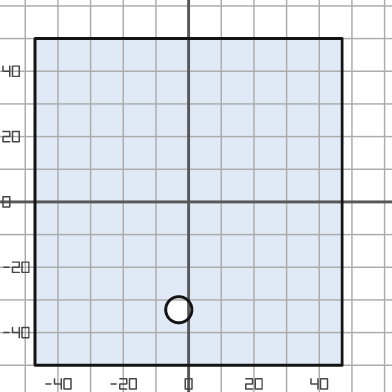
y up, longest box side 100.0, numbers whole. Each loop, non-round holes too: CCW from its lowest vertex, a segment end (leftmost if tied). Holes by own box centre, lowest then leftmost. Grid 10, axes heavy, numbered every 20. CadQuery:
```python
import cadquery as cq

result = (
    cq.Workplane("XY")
    .moveTo(-47.0, -50.0)
    .lineTo(47.0, -50.0)
    .lineTo(47.0, 50.0)
    .lineTo(-47.0, 50.0)
    .close()
    .moveTo(-3.0, -33.0)
    .circle(4.0)
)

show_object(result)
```